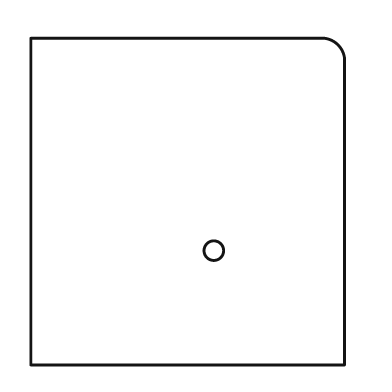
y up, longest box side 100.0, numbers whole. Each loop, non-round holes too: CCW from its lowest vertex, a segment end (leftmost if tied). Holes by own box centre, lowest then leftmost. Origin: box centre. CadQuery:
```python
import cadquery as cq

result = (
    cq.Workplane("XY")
    .moveTo(-48.0, -50.0)
    .lineTo(48.0, -50.0)
    .lineTo(48.0, 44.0)
    .threePointArc((46.0, 48.0), (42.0, 50.0))
    .lineTo(-48.0, 50.0)
    .close()
    .moveTo(8.0, -15.0)
    .circle(3.0)
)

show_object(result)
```